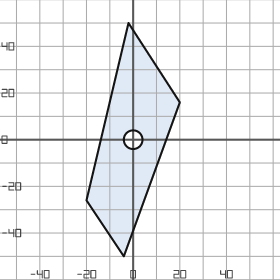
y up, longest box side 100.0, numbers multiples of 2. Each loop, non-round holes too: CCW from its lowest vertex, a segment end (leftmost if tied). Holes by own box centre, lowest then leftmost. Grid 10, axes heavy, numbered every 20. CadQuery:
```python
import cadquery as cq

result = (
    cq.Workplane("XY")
    .moveTo(-4.0, -50.0)
    .lineTo(20.0, 16.0)
    .lineTo(-2.0, 50.0)
    .lineTo(-20.0, -26.0)
    .close()
    .moveTo(0.0, 0.0)
    .circle(4.0)
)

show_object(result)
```